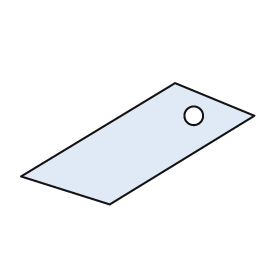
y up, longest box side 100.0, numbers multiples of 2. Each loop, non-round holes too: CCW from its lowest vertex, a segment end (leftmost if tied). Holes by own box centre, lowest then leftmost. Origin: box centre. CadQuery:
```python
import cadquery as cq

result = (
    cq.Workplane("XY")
    .moveTo(-12.0, -26.0)
    .lineTo(50.0, 12.0)
    .lineTo(16.0, 26.0)
    .lineTo(-50.0, -14.0)
    .close()
    .moveTo(24.0, 12.0)
    .circle(4.0)
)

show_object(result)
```